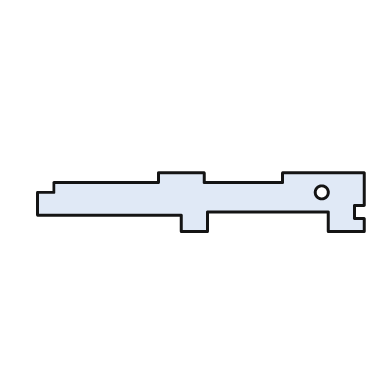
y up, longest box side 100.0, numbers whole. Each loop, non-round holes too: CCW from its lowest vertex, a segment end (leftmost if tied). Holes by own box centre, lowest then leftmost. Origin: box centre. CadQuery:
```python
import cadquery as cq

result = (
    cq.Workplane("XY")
    .moveTo(-6.0, -9.0)
    .lineTo(2.0, -9.0)
    .lineTo(2.0, -3.0)
    .lineTo(39.0, -3.0)
    .lineTo(39.0, -9.0)
    .lineTo(50.0, -9.0)
    .lineTo(50.0, -5.0)
    .lineTo(47.0, -5.0)
    .lineTo(47.0, -1.0)
    .lineTo(50.0, -1.0)
    .lineTo(50.0, 9.0)
    .lineTo(25.0, 9.0)
    .lineTo(25.0, 6.0)
    .lineTo(1.0, 6.0)
    .lineTo(1.0, 9.0)
    .lineTo(-13.0, 9.0)
    .lineTo(-13.0, 6.0)
    .lineTo(-45.0, 6.0)
    .lineTo(-45.0, 3.0)
    .lineTo(-50.0, 3.0)
    .lineTo(-50.0, -4.0)
    .lineTo(-6.0, -4.0)
    .close()
    .moveTo(37.0, 3.0)
    .circle(2.0)
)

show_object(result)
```